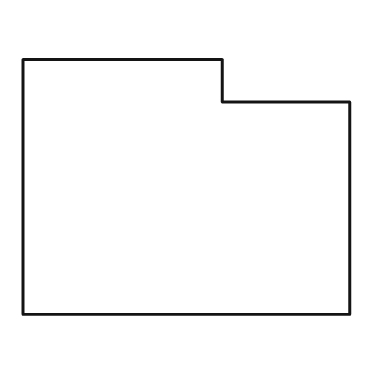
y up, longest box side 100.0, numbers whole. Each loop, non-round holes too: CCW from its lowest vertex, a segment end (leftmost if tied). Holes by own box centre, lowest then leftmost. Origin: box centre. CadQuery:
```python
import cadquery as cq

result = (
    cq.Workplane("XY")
    .moveTo(-50.0, -39.0)
    .lineTo(50.0, -39.0)
    .lineTo(50.0, 26.0)
    .lineTo(11.0, 26.0)
    .lineTo(11.0, 39.0)
    .lineTo(-50.0, 39.0)
    .close()
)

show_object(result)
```